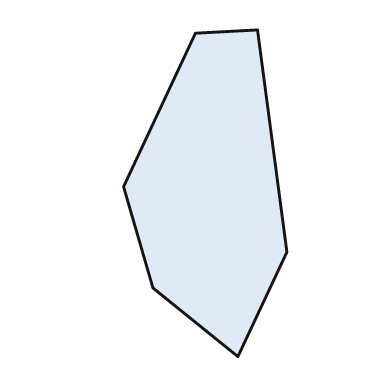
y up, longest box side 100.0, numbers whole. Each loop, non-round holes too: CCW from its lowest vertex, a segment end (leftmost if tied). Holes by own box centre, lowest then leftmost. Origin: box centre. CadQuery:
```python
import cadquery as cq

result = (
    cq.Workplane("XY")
    .moveTo(10.0, -50.0)
    .lineTo(25.0, -18.0)
    .lineTo(16.0, 50.0)
    .lineTo(-3.0, 49.0)
    .lineTo(-25.0, 2.0)
    .lineTo(-16.0, -29.0)
    .close()
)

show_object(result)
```